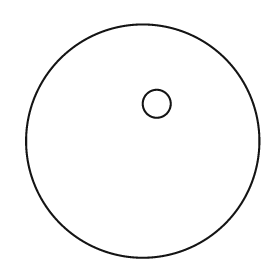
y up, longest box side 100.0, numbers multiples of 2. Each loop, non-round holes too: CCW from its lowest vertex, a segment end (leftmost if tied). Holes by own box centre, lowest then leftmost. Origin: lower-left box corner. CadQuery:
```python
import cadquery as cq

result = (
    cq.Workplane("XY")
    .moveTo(50.0, 50.0)
    .circle(50.0)
    .moveTo(56.0, 66.0)
    .circle(6.0)
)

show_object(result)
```